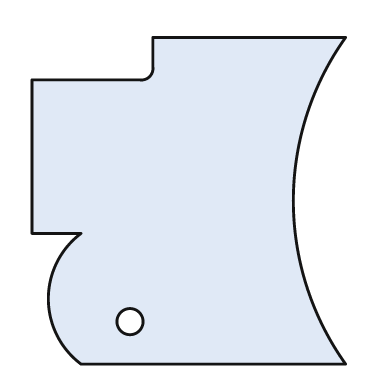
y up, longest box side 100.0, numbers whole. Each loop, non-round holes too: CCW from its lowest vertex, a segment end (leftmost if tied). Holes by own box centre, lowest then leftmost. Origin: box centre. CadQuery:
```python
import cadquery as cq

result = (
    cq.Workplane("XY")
    .moveTo(-33.0, -50.0)
    .lineTo(48.0, -50.0)
    .threePointArc((32.0, 0.0), (48.0, 50.0))
    .lineTo(-11.0, 50.0)
    .lineTo(-11.0, 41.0)
    .threePointArc((-12.0, 38.0), (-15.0, 37.0))
    .lineTo(-48.0, 37.0)
    .lineTo(-48.0, -10.0)
    .lineTo(-33.0, -10.0)
    .threePointArc((-43.0, -30.0), (-33.0, -50.0))
    .close()
    .moveTo(-18.0, -37.0)
    .circle(4.0)
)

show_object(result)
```